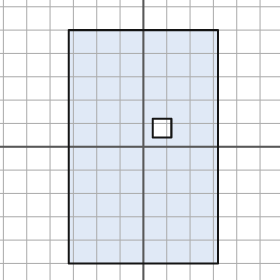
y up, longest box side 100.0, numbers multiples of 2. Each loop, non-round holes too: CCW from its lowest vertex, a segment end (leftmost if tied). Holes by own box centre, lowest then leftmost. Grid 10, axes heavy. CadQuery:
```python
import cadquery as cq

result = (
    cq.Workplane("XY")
    .moveTo(-32.0, -50.0)
    .lineTo(32.0, -50.0)
    .lineTo(32.0, 50.0)
    .lineTo(-32.0, 50.0)
    .close()
    .moveTo(4.0, 4.0)
    .lineTo(12.0, 4.0)
    .lineTo(12.0, 12.0)
    .lineTo(4.0, 12.0)
    .close()
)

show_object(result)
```